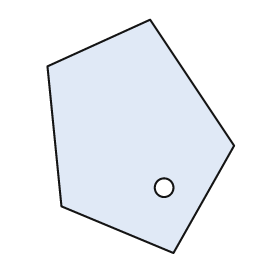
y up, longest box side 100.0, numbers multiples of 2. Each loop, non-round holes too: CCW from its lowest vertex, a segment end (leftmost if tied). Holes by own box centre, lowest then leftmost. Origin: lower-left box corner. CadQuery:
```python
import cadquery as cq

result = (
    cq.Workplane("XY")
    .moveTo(54.0, 0.0)
    .lineTo(80.0, 46.0)
    .lineTo(44.0, 100.0)
    .lineTo(0.0, 80.0)
    .lineTo(6.0, 20.0)
    .close()
    .moveTo(50.0, 28.0)
    .circle(4.0)
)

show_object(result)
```